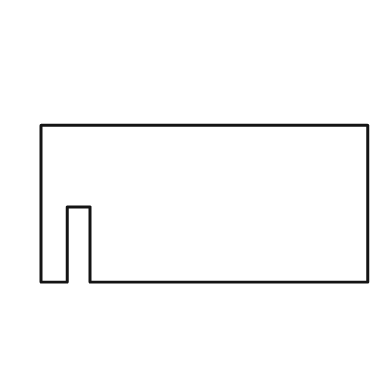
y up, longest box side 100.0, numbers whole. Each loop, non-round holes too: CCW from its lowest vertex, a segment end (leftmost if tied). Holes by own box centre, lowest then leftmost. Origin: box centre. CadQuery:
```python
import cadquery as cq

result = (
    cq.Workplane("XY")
    .moveTo(-50.0, -24.0)
    .lineTo(-42.0, -24.0)
    .lineTo(-42.0, -1.0)
    .lineTo(-35.0, -1.0)
    .lineTo(-35.0, -24.0)
    .lineTo(50.0, -24.0)
    .lineTo(50.0, 24.0)
    .lineTo(-50.0, 24.0)
    .close()
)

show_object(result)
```